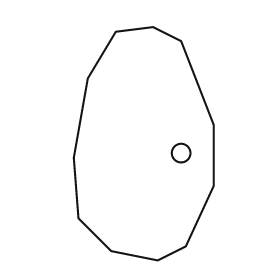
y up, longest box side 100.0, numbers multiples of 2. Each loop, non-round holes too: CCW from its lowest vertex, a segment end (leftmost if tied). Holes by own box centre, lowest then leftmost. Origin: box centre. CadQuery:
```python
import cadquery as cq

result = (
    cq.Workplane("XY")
    .moveTo(6.0, -50.0)
    .lineTo(18.0, -44.0)
    .lineTo(30.0, -18.0)
    .lineTo(30.0, 8.0)
    .lineTo(16.0, 44.0)
    .lineTo(4.0, 50.0)
    .lineTo(-12.0, 48.0)
    .lineTo(-24.0, 28.0)
    .lineTo(-30.0, -6.0)
    .lineTo(-28.0, -32.0)
    .lineTo(-14.0, -46.0)
    .close()
    .moveTo(16.0, -4.0)
    .circle(4.0)
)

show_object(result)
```